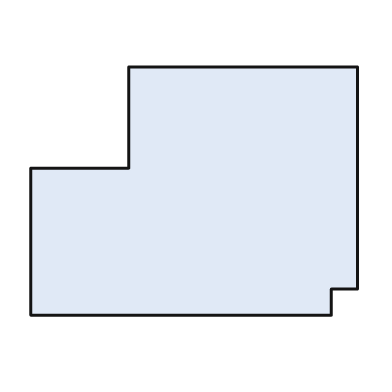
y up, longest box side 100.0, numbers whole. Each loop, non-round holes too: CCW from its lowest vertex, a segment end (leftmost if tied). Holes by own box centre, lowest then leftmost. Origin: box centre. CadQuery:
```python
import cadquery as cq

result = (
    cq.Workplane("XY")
    .moveTo(-50.0, -38.0)
    .lineTo(42.0, -38.0)
    .lineTo(42.0, -30.0)
    .lineTo(50.0, -30.0)
    .lineTo(50.0, 38.0)
    .lineTo(-20.0, 38.0)
    .lineTo(-20.0, 7.0)
    .lineTo(-50.0, 7.0)
    .close()
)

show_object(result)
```